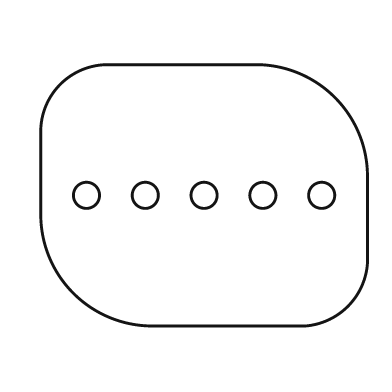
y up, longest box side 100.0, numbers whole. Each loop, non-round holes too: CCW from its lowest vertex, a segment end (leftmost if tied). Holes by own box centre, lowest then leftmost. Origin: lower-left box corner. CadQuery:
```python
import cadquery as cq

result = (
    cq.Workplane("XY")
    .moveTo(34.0, 0.0)
    .lineTo(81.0, 0.0)
    .threePointArc((94.0, 6.0), (100.0, 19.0))
    .lineTo(100.0, 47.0)
    .threePointArc((90.0, 70.0), (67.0, 80.0))
    .lineTo(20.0, 80.0)
    .threePointArc((6.0, 74.0), (0.0, 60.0))
    .lineTo(0.0, 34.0)
    .threePointArc((10.0, 10.0), (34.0, 0.0))
    .close()
    .moveTo(14.0, 40.0)
    .circle(4.0)
    .moveTo(32.0, 40.0)
    .circle(4.0)
    .moveTo(50.0, 40.0)
    .circle(4.0)
    .moveTo(68.0, 40.0)
    .circle(4.0)
    .moveTo(86.0, 40.0)
    .circle(4.0)
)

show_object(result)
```